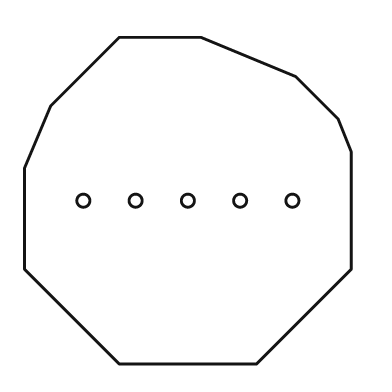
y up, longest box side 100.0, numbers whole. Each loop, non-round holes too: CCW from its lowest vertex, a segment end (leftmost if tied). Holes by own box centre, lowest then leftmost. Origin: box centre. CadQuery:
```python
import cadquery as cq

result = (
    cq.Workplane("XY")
    .moveTo(-21.0, -50.0)
    .lineTo(21.0, -50.0)
    .lineTo(50.0, -21.0)
    .lineTo(50.0, 15.0)
    .lineTo(46.0, 25.0)
    .lineTo(33.0, 38.0)
    .lineTo(4.0, 50.0)
    .lineTo(-21.0, 50.0)
    .lineTo(-42.0, 29.0)
    .lineTo(-50.0, 10.0)
    .lineTo(-50.0, -21.0)
    .close()
    .moveTo(-32.0, 0.0)
    .circle(2.0)
    .moveTo(-16.0, 0.0)
    .circle(2.0)
    .moveTo(0.0, 0.0)
    .circle(2.0)
    .moveTo(16.0, 0.0)
    .circle(2.0)
    .moveTo(32.0, 0.0)
    .circle(2.0)
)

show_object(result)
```